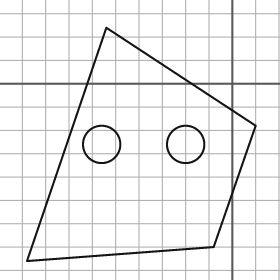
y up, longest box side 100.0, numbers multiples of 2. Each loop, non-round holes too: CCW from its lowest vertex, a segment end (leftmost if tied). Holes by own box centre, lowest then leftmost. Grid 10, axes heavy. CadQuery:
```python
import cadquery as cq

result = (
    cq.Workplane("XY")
    .moveTo(-88.0, -76.0)
    .lineTo(-8.0, -70.0)
    .lineTo(10.0, -18.0)
    .lineTo(-54.0, 24.0)
    .close()
    .moveTo(-56.0, -26.0)
    .circle(8.0)
    .moveTo(-20.0, -26.0)
    .circle(8.0)
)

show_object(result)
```